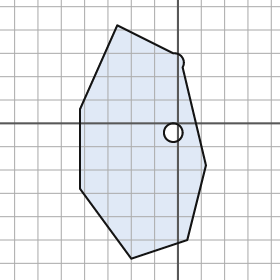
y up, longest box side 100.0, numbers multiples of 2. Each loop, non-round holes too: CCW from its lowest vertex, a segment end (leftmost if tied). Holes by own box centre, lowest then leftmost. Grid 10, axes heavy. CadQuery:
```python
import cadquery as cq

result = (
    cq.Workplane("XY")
    .moveTo(-20.0, -58.0)
    .lineTo(4.0, -50.0)
    .lineTo(12.0, -18.0)
    .lineTo(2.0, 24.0)
    .threePointArc((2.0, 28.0), (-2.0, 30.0))
    .lineTo(-26.0, 42.0)
    .lineTo(-42.0, 6.0)
    .lineTo(-42.0, -28.0)
    .close()
    .moveTo(-2.0, -4.0)
    .circle(4.0)
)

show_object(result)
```